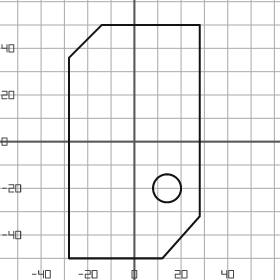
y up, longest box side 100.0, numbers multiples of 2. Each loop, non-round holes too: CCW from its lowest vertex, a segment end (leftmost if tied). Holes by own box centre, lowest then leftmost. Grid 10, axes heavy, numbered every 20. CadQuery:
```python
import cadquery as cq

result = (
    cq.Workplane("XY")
    .moveTo(-28.0, -50.0)
    .lineTo(12.0, -50.0)
    .lineTo(28.0, -32.0)
    .lineTo(28.0, 50.0)
    .lineTo(-14.0, 50.0)
    .lineTo(-28.0, 36.0)
    .close()
    .moveTo(14.0, -20.0)
    .circle(6.0)
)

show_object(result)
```